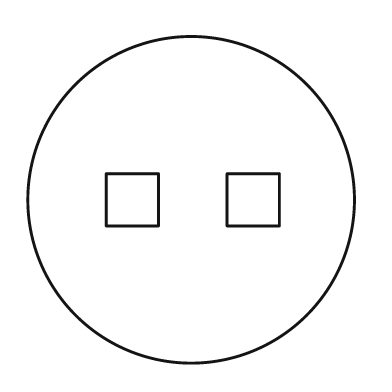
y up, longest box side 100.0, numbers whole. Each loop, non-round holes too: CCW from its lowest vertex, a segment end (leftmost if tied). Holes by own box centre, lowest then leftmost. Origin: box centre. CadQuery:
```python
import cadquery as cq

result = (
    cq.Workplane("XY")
    .moveTo(0.0, 0.0)
    .circle(50.0)
    .moveTo(-26.0, -8.0)
    .lineTo(-10.0, -8.0)
    .lineTo(-10.0, 8.0)
    .lineTo(-26.0, 8.0)
    .close()
    .moveTo(11.0, -8.0)
    .lineTo(27.0, -8.0)
    .lineTo(27.0, 8.0)
    .lineTo(11.0, 8.0)
    .close()
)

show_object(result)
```